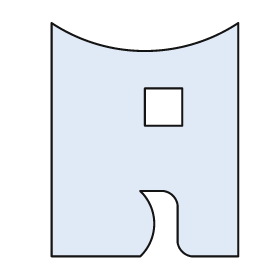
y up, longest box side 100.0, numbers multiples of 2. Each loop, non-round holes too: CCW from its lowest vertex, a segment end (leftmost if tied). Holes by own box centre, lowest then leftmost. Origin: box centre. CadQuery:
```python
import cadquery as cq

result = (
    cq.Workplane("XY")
    .moveTo(-40.0, -50.0)
    .lineTo(-2.0, -50.0)
    .threePointArc((4.0, -36.0), (-2.0, -22.0))
    .lineTo(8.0, -22.0)
    .threePointArc((12.0, -24.0), (14.0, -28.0))
    .lineTo(14.0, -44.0)
    .threePointArc((16.0, -48.0), (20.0, -50.0))
    .lineTo(40.0, -50.0)
    .lineTo(40.0, 50.0)
    .threePointArc((0.0, 38.0), (-40.0, 50.0))
    .close()
    .moveTo(0.0, 6.0)
    .lineTo(16.0, 6.0)
    .lineTo(16.0, 22.0)
    .lineTo(0.0, 22.0)
    .close()
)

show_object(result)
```